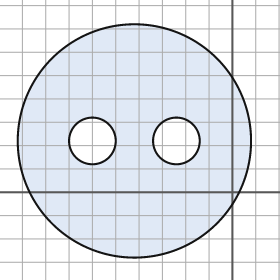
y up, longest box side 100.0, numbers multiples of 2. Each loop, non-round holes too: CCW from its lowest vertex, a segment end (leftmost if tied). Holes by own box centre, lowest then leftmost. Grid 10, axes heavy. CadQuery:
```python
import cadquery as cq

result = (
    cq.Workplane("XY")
    .moveTo(-42.0, 22.0)
    .circle(50.0)
    .moveTo(-60.0, 22.0)
    .circle(10.0)
    .moveTo(-24.0, 22.0)
    .circle(10.0)
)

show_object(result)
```